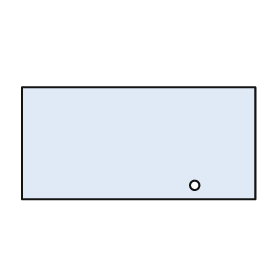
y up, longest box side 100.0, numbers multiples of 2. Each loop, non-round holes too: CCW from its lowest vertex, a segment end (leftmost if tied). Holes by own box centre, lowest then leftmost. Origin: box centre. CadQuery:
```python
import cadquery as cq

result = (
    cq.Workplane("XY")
    .moveTo(-50.0, -24.0)
    .lineTo(50.0, -24.0)
    .lineTo(50.0, 24.0)
    .lineTo(-50.0, 24.0)
    .close()
    .moveTo(24.0, -18.0)
    .circle(2.0)
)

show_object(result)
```